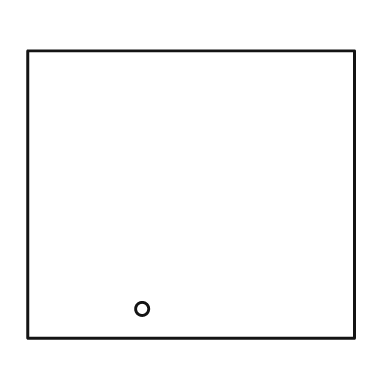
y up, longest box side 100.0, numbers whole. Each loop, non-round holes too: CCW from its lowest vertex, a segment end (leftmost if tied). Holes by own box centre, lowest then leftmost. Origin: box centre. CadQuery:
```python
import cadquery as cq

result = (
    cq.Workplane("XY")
    .moveTo(-50.0, -44.0)
    .lineTo(50.0, -44.0)
    .lineTo(50.0, 44.0)
    .lineTo(-50.0, 44.0)
    .close()
    .moveTo(-15.0, -35.0)
    .circle(2.0)
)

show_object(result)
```